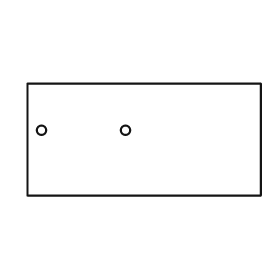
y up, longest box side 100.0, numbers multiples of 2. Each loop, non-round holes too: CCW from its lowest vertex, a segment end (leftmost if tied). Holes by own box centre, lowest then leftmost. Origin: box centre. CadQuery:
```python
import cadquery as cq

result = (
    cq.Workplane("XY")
    .moveTo(-50.0, -24.0)
    .lineTo(50.0, -24.0)
    .lineTo(50.0, 24.0)
    .lineTo(-50.0, 24.0)
    .close()
    .moveTo(-44.0, 4.0)
    .circle(2.0)
    .moveTo(-8.0, 4.0)
    .circle(2.0)
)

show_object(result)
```